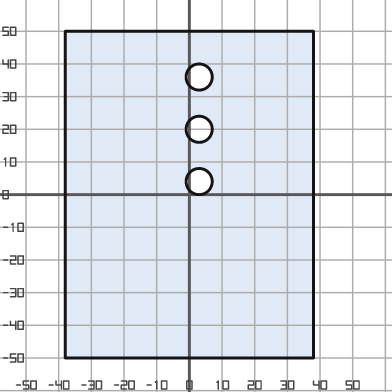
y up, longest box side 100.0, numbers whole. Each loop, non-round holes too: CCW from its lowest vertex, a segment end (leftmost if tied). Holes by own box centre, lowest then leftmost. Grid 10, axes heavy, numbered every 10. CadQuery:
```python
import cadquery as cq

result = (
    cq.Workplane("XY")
    .moveTo(-38.0, -50.0)
    .lineTo(38.0, -50.0)
    .lineTo(38.0, 50.0)
    .lineTo(-38.0, 50.0)
    .close()
    .moveTo(3.0, 4.0)
    .circle(4.0)
    .moveTo(3.0, 20.0)
    .circle(4.0)
    .moveTo(3.0, 36.0)
    .circle(4.0)
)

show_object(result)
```